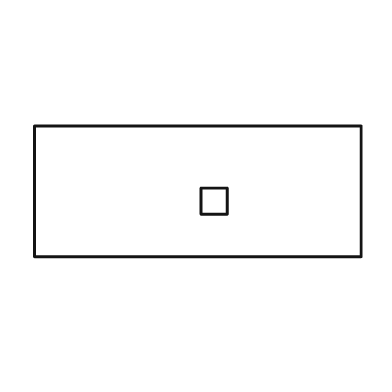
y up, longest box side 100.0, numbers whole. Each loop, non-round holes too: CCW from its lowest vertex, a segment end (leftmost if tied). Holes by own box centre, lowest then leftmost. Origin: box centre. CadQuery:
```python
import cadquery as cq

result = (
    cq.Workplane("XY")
    .moveTo(-50.0, -20.0)
    .lineTo(50.0, -20.0)
    .lineTo(50.0, 20.0)
    .lineTo(-50.0, 20.0)
    .close()
    .moveTo(1.0, -7.0)
    .lineTo(9.0, -7.0)
    .lineTo(9.0, 1.0)
    .lineTo(1.0, 1.0)
    .close()
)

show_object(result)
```